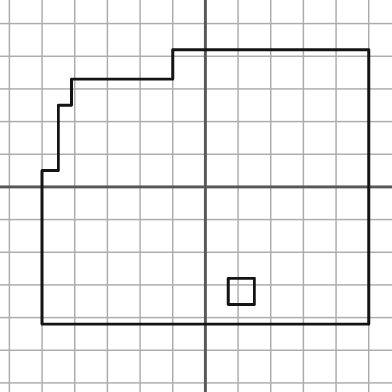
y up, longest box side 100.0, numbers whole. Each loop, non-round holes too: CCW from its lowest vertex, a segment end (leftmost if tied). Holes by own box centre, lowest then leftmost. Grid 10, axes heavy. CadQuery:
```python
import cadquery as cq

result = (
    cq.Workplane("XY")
    .moveTo(-50.0, -42.0)
    .lineTo(50.0, -42.0)
    .lineTo(50.0, 42.0)
    .lineTo(-10.0, 42.0)
    .lineTo(-10.0, 33.0)
    .lineTo(-41.0, 33.0)
    .lineTo(-41.0, 25.0)
    .lineTo(-45.0, 25.0)
    .lineTo(-45.0, 5.0)
    .lineTo(-50.0, 5.0)
    .close()
    .moveTo(7.0, -36.0)
    .lineTo(15.0, -36.0)
    .lineTo(15.0, -28.0)
    .lineTo(7.0, -28.0)
    .close()
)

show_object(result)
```